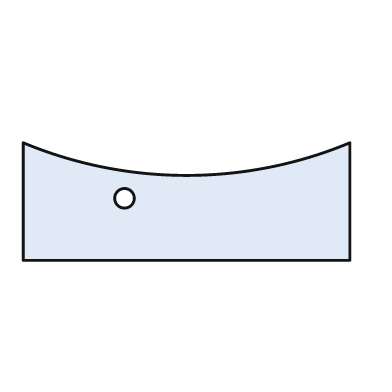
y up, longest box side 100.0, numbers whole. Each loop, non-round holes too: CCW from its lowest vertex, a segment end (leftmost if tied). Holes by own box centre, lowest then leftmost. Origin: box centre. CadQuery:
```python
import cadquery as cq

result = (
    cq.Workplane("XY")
    .moveTo(-50.0, -18.0)
    .lineTo(50.0, -18.0)
    .lineTo(50.0, 18.0)
    .threePointArc((0.0, 8.0), (-50.0, 18.0))
    .close()
    .moveTo(-19.0, 1.0)
    .circle(3.0)
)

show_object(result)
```